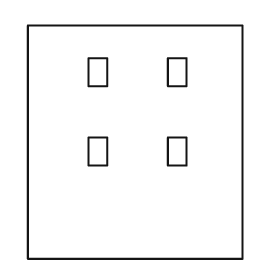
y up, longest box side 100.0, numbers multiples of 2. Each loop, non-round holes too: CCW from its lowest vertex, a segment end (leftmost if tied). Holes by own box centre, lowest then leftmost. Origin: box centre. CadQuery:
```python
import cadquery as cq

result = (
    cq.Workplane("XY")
    .moveTo(-46.0, -50.0)
    .lineTo(46.0, -50.0)
    .lineTo(46.0, 50.0)
    .lineTo(-46.0, 50.0)
    .close()
    .moveTo(-20.0, -10.0)
    .lineTo(-12.0, -10.0)
    .lineTo(-12.0, 2.0)
    .lineTo(-20.0, 2.0)
    .close()
    .moveTo(14.0, -10.0)
    .lineTo(22.0, -10.0)
    .lineTo(22.0, 2.0)
    .lineTo(14.0, 2.0)
    .close()
    .moveTo(-20.0, 24.0)
    .lineTo(-12.0, 24.0)
    .lineTo(-12.0, 36.0)
    .lineTo(-20.0, 36.0)
    .close()
    .moveTo(14.0, 24.0)
    .lineTo(22.0, 24.0)
    .lineTo(22.0, 36.0)
    .lineTo(14.0, 36.0)
    .close()
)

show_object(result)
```